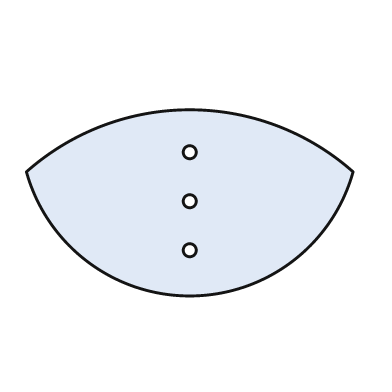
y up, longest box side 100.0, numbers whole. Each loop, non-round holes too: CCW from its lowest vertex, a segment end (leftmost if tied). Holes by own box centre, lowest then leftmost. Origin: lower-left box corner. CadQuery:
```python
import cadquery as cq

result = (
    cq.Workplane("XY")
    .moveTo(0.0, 38.0)
    .threePointArc((50.0, 0.0), (100.0, 38.0))
    .threePointArc((50.0, 57.0), (0.0, 38.0))
    .close()
    .moveTo(50.0, 14.0)
    .circle(2.0)
    .moveTo(50.0, 29.0)
    .circle(2.0)
    .moveTo(50.0, 44.0)
    .circle(2.0)
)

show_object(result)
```